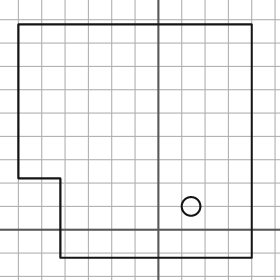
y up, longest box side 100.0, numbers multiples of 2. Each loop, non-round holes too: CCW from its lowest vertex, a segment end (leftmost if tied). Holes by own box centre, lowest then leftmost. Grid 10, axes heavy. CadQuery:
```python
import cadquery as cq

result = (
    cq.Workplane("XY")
    .moveTo(-42.0, -12.0)
    .lineTo(40.0, -12.0)
    .lineTo(40.0, 88.0)
    .lineTo(-60.0, 88.0)
    .lineTo(-60.0, 22.0)
    .lineTo(-42.0, 22.0)
    .close()
    .moveTo(14.0, 10.0)
    .circle(4.0)
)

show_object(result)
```